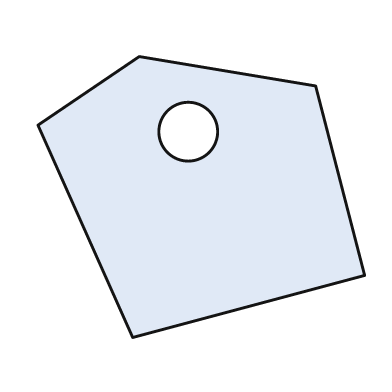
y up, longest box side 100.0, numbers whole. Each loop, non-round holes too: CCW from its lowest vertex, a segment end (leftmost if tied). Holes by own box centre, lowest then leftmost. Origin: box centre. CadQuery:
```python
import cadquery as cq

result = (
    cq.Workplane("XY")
    .moveTo(-21.0, -43.0)
    .lineTo(50.0, -24.0)
    .lineTo(35.0, 34.0)
    .lineTo(-19.0, 43.0)
    .lineTo(-50.0, 22.0)
    .close()
    .moveTo(-4.0, 20.0)
    .circle(9.0)
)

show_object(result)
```